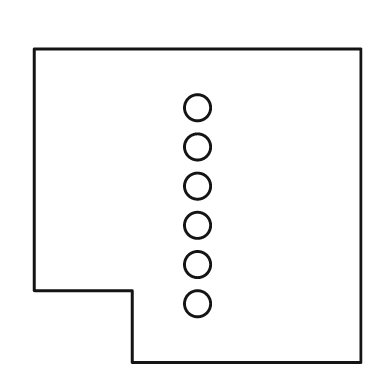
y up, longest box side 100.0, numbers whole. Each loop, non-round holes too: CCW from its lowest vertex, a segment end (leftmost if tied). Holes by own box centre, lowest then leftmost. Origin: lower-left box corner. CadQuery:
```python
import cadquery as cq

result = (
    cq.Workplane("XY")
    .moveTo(30.0, 0.0)
    .lineTo(100.0, 0.0)
    .lineTo(100.0, 96.0)
    .lineTo(0.0, 96.0)
    .lineTo(0.0, 22.0)
    .lineTo(30.0, 22.0)
    .close()
    .moveTo(50.0, 18.0)
    .circle(4.0)
    .moveTo(50.0, 30.0)
    .circle(4.0)
    .moveTo(50.0, 42.0)
    .circle(4.0)
    .moveTo(50.0, 54.0)
    .circle(4.0)
    .moveTo(50.0, 66.0)
    .circle(4.0)
    .moveTo(50.0, 78.0)
    .circle(4.0)
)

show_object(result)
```